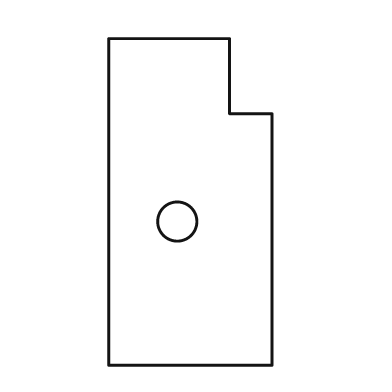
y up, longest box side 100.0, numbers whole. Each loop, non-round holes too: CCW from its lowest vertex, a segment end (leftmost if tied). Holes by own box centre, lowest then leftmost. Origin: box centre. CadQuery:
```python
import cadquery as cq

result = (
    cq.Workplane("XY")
    .moveTo(-25.0, -50.0)
    .lineTo(25.0, -50.0)
    .lineTo(25.0, 27.0)
    .lineTo(12.0, 27.0)
    .lineTo(12.0, 50.0)
    .lineTo(-25.0, 50.0)
    .close()
    .moveTo(-4.0, -6.0)
    .circle(6.0)
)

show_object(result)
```